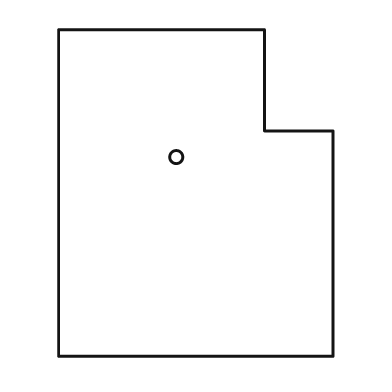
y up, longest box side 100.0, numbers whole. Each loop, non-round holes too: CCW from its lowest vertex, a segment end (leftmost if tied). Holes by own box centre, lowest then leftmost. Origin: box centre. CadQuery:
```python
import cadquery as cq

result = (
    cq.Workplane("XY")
    .moveTo(-42.0, -50.0)
    .lineTo(42.0, -50.0)
    .lineTo(42.0, 19.0)
    .lineTo(21.0, 19.0)
    .lineTo(21.0, 50.0)
    .lineTo(-42.0, 50.0)
    .close()
    .moveTo(-6.0, 11.0)
    .circle(2.0)
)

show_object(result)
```